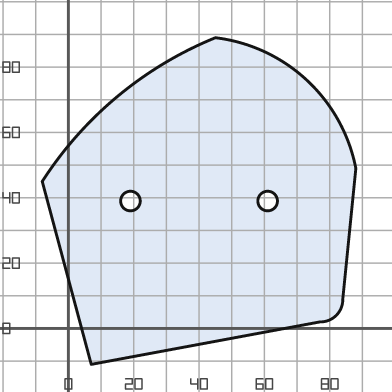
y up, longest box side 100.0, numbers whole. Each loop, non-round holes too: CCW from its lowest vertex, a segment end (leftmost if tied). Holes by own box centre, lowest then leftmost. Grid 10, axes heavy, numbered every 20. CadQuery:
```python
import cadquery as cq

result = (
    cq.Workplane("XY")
    .moveTo(7.0, -11.0)
    .lineTo(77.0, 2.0)
    .threePointArc((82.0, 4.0), (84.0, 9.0))
    .lineTo(88.0, 49.0)
    .threePointArc((73.0, 76.0), (45.0, 89.0))
    .threePointArc((15.0, 71.0), (-8.0, 45.0))
    .close()
    .moveTo(19.0, 39.0)
    .circle(3.0)
    .moveTo(61.0, 39.0)
    .circle(3.0)
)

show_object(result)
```